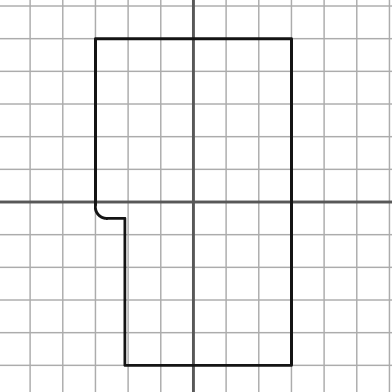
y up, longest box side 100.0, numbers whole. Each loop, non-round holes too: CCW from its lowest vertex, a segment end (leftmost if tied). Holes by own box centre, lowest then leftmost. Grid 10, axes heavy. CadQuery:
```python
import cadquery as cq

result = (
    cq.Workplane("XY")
    .moveTo(-21.0, -50.0)
    .lineTo(30.0, -50.0)
    .lineTo(30.0, 50.0)
    .lineTo(-30.0, 50.0)
    .lineTo(-30.0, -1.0)
    .threePointArc((-29.0, -4.0), (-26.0, -5.0))
    .lineTo(-21.0, -5.0)
    .close()
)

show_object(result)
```